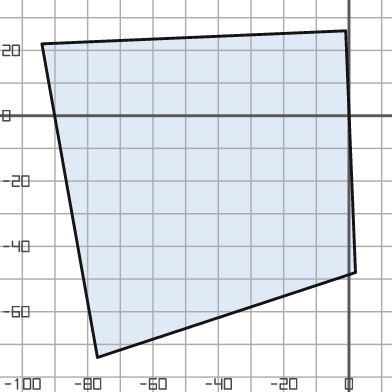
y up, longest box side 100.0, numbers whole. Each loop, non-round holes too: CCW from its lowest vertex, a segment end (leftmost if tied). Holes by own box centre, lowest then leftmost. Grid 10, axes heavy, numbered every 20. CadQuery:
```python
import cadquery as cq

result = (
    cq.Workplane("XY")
    .moveTo(-77.0, -74.0)
    .lineTo(2.0, -48.0)
    .lineTo(-1.0, 26.0)
    .lineTo(-94.0, 22.0)
    .close()
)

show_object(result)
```